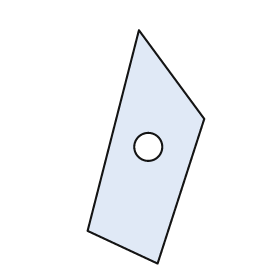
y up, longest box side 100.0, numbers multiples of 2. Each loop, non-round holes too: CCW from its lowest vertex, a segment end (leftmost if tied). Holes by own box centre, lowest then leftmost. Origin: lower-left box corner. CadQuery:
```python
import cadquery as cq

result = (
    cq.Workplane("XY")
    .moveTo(30.0, 0.0)
    .lineTo(50.0, 62.0)
    .lineTo(22.0, 100.0)
    .lineTo(0.0, 14.0)
    .close()
    .moveTo(26.0, 50.0)
    .circle(6.0)
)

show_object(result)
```